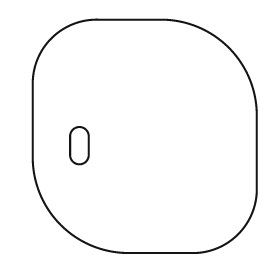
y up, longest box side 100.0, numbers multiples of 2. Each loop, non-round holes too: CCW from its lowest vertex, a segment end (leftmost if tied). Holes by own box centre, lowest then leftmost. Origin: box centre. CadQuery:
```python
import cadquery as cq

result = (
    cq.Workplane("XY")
    .moveTo(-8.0, -50.0)
    .lineTo(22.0, -50.0)
    .threePointArc((40.0, -42.0), (48.0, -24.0))
    .lineTo(48.0, 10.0)
    .threePointArc((36.0, 38.0), (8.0, 50.0))
    .lineTo(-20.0, 50.0)
    .threePointArc((-40.0, 42.0), (-48.0, 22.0))
    .lineTo(-48.0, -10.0)
    .threePointArc((-36.0, -38.0), (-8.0, -50.0))
    .close()
    .moveTo(-32.0, -8.0)
    .threePointArc((-28.0, -12.0), (-24.0, -8.0))
    .lineTo(-24.0, 0.0)
    .threePointArc((-28.0, 4.0), (-32.0, 0.0))
    .close()
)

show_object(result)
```